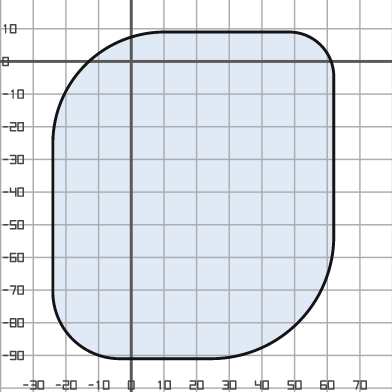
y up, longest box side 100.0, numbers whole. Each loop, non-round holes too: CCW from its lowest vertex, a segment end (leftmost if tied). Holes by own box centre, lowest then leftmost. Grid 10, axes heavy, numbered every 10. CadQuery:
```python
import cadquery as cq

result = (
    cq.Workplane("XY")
    .moveTo(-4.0, -91.0)
    .lineTo(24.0, -91.0)
    .threePointArc((51.0, -80.0), (62.0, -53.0))
    .lineTo(62.0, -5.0)
    .threePointArc((58.0, 5.0), (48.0, 9.0))
    .lineTo(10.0, 9.0)
    .threePointArc((-14.0, -1.0), (-24.0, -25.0))
    .lineTo(-24.0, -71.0)
    .threePointArc((-18.0, -85.0), (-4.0, -91.0))
    .close()
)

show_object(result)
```